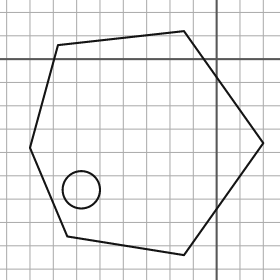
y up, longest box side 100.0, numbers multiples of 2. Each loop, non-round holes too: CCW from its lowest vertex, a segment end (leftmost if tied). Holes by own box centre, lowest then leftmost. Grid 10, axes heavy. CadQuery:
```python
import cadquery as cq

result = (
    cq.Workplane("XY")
    .moveTo(-14.0, -84.0)
    .lineTo(20.0, -36.0)
    .lineTo(-14.0, 12.0)
    .lineTo(-68.0, 6.0)
    .lineTo(-80.0, -38.0)
    .lineTo(-64.0, -76.0)
    .close()
    .moveTo(-58.0, -56.0)
    .circle(8.0)
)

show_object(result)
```